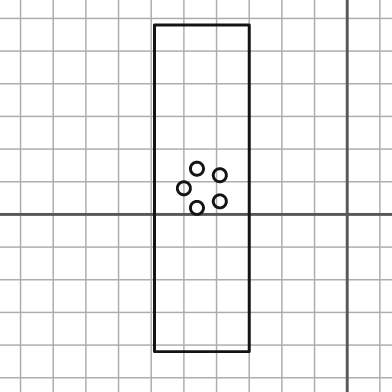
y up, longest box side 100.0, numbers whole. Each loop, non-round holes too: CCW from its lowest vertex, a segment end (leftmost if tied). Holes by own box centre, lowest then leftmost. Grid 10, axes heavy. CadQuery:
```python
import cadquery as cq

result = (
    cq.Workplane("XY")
    .moveTo(-59.0, -42.0)
    .lineTo(-30.0, -42.0)
    .lineTo(-30.0, 58.0)
    .lineTo(-59.0, 58.0)
    .close()
    .moveTo(-46.0, 2.0)
    .circle(2.0)
    .moveTo(-39.0, 4.0)
    .circle(2.0)
    .moveTo(-50.0, 8.0)
    .circle(2.0)
    .moveTo(-39.0, 12.0)
    .circle(2.0)
    .moveTo(-46.0, 14.0)
    .circle(2.0)
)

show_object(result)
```